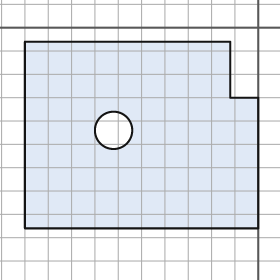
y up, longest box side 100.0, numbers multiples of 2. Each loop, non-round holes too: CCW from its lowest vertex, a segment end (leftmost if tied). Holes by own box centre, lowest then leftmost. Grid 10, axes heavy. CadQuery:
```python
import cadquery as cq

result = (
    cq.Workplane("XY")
    .moveTo(-100.0, -86.0)
    .lineTo(0.0, -86.0)
    .lineTo(0.0, -30.0)
    .lineTo(-12.0, -30.0)
    .lineTo(-12.0, -6.0)
    .lineTo(-100.0, -6.0)
    .close()
    .moveTo(-62.0, -44.0)
    .circle(8.0)
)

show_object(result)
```